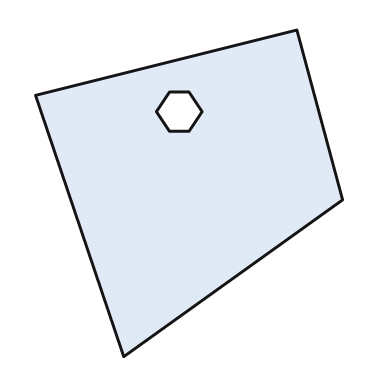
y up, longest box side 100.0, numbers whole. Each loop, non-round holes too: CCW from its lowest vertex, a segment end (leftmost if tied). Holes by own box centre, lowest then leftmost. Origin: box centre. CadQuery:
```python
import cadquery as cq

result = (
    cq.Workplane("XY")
    .moveTo(-20.0, -50.0)
    .lineTo(47.0, -2.0)
    .lineTo(33.0, 50.0)
    .lineTo(-47.0, 30.0)
    .close()
    .moveTo(-6.0, 19.0)
    .lineTo(0.0, 19.0)
    .lineTo(4.0, 25.0)
    .lineTo(0.0, 31.0)
    .lineTo(-6.0, 31.0)
    .lineTo(-10.0, 25.0)
    .close()
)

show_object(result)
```